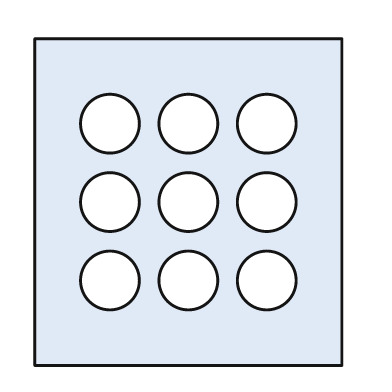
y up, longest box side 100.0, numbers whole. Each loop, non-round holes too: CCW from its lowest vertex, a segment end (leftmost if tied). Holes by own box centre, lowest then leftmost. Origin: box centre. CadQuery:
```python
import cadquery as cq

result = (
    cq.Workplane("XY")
    .moveTo(-47.0, -50.0)
    .lineTo(47.0, -50.0)
    .lineTo(47.0, 50.0)
    .lineTo(-47.0, 50.0)
    .close()
    .moveTo(-24.0, -24.0)
    .circle(9.0)
    .moveTo(0.0, -24.0)
    .circle(9.0)
    .moveTo(24.0, -24.0)
    .circle(9.0)
    .moveTo(-24.0, 0.0)
    .circle(9.0)
    .moveTo(0.0, 0.0)
    .circle(9.0)
    .moveTo(24.0, 0.0)
    .circle(9.0)
    .moveTo(-24.0, 24.0)
    .circle(9.0)
    .moveTo(0.0, 24.0)
    .circle(9.0)
    .moveTo(24.0, 24.0)
    .circle(9.0)
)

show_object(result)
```